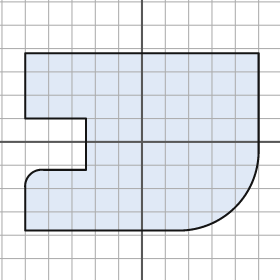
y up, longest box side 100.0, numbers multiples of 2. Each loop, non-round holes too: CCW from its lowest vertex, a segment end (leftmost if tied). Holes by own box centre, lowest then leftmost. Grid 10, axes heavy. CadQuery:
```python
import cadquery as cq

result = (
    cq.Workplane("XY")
    .moveTo(-50.0, -38.0)
    .lineTo(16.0, -38.0)
    .threePointArc((40.0, -28.0), (50.0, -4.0))
    .lineTo(50.0, 38.0)
    .lineTo(-50.0, 38.0)
    .lineTo(-50.0, 10.0)
    .lineTo(-24.0, 10.0)
    .lineTo(-24.0, -12.0)
    .lineTo(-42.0, -12.0)
    .threePointArc((-48.0, -14.0), (-50.0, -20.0))
    .close()
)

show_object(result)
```